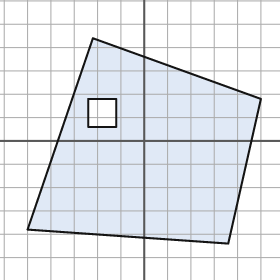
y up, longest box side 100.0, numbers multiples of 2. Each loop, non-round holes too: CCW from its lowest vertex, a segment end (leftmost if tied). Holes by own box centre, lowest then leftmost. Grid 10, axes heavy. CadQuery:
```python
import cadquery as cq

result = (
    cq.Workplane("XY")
    .moveTo(36.0, -44.0)
    .lineTo(50.0, 18.0)
    .lineTo(-22.0, 44.0)
    .lineTo(-50.0, -38.0)
    .close()
    .moveTo(-24.0, 6.0)
    .lineTo(-12.0, 6.0)
    .lineTo(-12.0, 18.0)
    .lineTo(-24.0, 18.0)
    .close()
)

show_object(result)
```